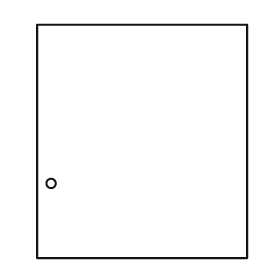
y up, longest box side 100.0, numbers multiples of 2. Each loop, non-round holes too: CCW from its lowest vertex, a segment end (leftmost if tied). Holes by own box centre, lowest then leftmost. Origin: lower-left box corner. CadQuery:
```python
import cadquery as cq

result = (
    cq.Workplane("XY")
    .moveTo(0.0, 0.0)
    .lineTo(90.0, 0.0)
    .lineTo(90.0, 100.0)
    .lineTo(0.0, 100.0)
    .close()
    .moveTo(6.0, 32.0)
    .circle(2.0)
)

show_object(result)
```